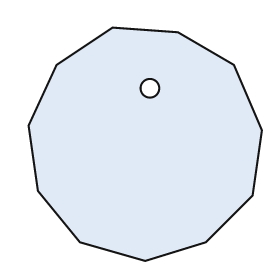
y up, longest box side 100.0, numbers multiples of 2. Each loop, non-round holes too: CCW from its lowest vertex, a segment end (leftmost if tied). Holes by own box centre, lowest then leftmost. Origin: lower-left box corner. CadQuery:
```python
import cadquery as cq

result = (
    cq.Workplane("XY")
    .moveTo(50.0, 0.0)
    .lineTo(76.0, 8.0)
    .lineTo(96.0, 28.0)
    .lineTo(100.0, 56.0)
    .lineTo(88.0, 84.0)
    .lineTo(64.0, 98.0)
    .lineTo(36.0, 100.0)
    .lineTo(12.0, 84.0)
    .lineTo(0.0, 58.0)
    .lineTo(4.0, 30.0)
    .lineTo(22.0, 8.0)
    .close()
    .moveTo(52.0, 74.0)
    .circle(4.0)
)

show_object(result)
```